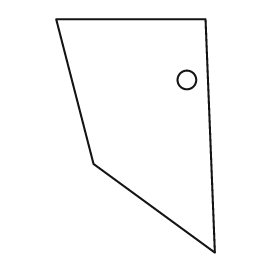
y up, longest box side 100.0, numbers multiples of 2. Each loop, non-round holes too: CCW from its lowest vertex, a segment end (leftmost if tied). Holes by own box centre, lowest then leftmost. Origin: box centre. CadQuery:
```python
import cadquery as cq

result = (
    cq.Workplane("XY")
    .moveTo(34.0, -50.0)
    .lineTo(30.0, 50.0)
    .lineTo(-34.0, 50.0)
    .lineTo(-18.0, -12.0)
    .close()
    .moveTo(22.0, 24.0)
    .circle(4.0)
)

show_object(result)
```